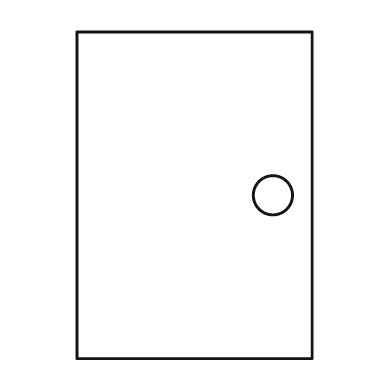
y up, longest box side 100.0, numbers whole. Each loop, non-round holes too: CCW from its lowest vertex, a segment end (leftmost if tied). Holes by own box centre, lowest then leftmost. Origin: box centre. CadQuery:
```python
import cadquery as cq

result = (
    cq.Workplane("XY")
    .moveTo(-36.0, -50.0)
    .lineTo(36.0, -50.0)
    .lineTo(36.0, 50.0)
    .lineTo(-36.0, 50.0)
    .close()
    .moveTo(24.0, 0.0)
    .circle(6.0)
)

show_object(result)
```